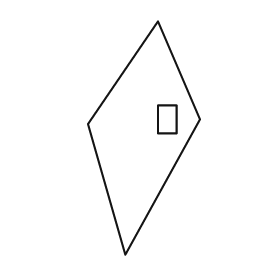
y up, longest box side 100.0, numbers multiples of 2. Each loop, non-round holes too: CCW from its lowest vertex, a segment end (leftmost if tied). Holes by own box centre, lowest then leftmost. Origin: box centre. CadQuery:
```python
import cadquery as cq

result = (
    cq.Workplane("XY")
    .moveTo(-8.0, -50.0)
    .lineTo(24.0, 8.0)
    .lineTo(6.0, 50.0)
    .lineTo(-24.0, 6.0)
    .close()
    .moveTo(6.0, 2.0)
    .lineTo(14.0, 2.0)
    .lineTo(14.0, 14.0)
    .lineTo(6.0, 14.0)
    .close()
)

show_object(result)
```